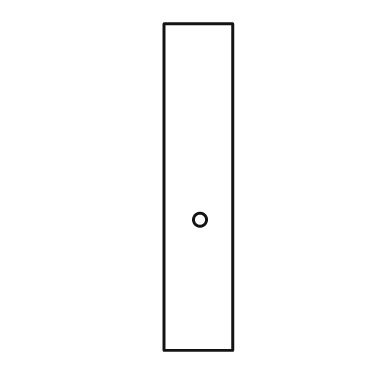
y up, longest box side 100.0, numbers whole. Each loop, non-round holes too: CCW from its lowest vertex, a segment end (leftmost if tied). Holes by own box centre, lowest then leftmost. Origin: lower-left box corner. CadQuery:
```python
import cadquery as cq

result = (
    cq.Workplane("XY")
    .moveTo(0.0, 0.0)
    .lineTo(21.0, 0.0)
    .lineTo(21.0, 100.0)
    .lineTo(0.0, 100.0)
    .close()
    .moveTo(11.0, 40.0)
    .circle(2.0)
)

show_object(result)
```